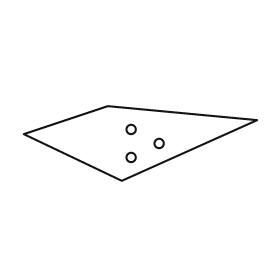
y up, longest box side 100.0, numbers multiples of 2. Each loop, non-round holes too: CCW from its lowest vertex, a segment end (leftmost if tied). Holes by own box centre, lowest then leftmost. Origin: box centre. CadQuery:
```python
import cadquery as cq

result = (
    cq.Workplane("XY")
    .moveTo(-8.0, -16.0)
    .lineTo(50.0, 10.0)
    .lineTo(-14.0, 16.0)
    .lineTo(-50.0, 4.0)
    .close()
    .moveTo(-4.0, -6.0)
    .circle(2.0)
    .moveTo(8.0, 0.0)
    .circle(2.0)
    .moveTo(-4.0, 6.0)
    .circle(2.0)
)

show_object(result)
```